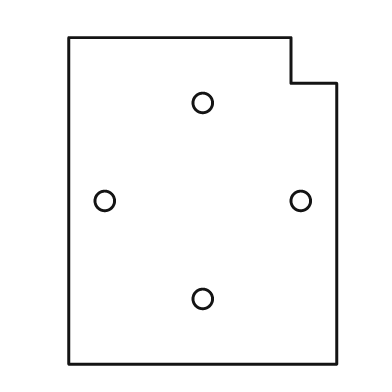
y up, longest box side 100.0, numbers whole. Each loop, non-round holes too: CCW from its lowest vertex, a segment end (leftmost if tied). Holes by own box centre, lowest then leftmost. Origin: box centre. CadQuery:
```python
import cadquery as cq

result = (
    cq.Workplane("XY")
    .moveTo(-41.0, -50.0)
    .lineTo(41.0, -50.0)
    .lineTo(41.0, 36.0)
    .lineTo(27.0, 36.0)
    .lineTo(27.0, 50.0)
    .lineTo(-41.0, 50.0)
    .close()
    .moveTo(0.0, -30.0)
    .circle(3.0)
    .moveTo(-30.0, 0.0)
    .circle(3.0)
    .moveTo(30.0, 0.0)
    .circle(3.0)
    .moveTo(0.0, 30.0)
    .circle(3.0)
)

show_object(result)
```